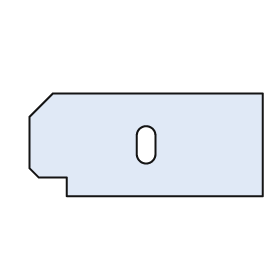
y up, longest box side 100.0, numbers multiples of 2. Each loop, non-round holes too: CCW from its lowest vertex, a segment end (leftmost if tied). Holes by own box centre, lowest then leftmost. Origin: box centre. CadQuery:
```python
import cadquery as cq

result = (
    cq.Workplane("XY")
    .moveTo(-34.0, -22.0)
    .lineTo(50.0, -22.0)
    .lineTo(50.0, 22.0)
    .lineTo(-40.0, 22.0)
    .lineTo(-50.0, 12.0)
    .lineTo(-50.0, -10.0)
    .lineTo(-46.0, -14.0)
    .lineTo(-34.0, -14.0)
    .close()
    .moveTo(-4.0, -4.0)
    .threePointArc((0.0, -8.0), (4.0, -4.0))
    .lineTo(4.0, 4.0)
    .threePointArc((0.0, 8.0), (-4.0, 4.0))
    .close()
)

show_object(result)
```